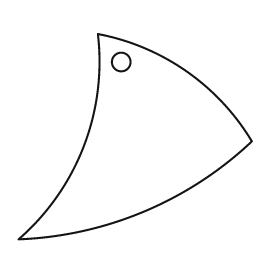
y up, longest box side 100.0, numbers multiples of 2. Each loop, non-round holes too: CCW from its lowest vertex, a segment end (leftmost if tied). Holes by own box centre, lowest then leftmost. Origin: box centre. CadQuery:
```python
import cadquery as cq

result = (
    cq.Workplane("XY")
    .moveTo(-50.0, -44.0)
    .threePointArc((4.0, -32.0), (50.0, -2.0))
    .threePointArc((22.0, 28.0), (-16.0, 44.0))
    .threePointArc((-22.0, -4.0), (-50.0, -44.0))
    .close()
    .moveTo(-6.0, 32.0)
    .circle(4.0)
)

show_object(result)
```